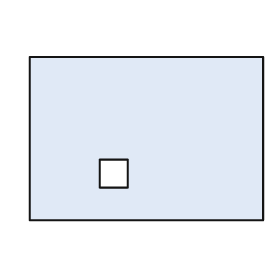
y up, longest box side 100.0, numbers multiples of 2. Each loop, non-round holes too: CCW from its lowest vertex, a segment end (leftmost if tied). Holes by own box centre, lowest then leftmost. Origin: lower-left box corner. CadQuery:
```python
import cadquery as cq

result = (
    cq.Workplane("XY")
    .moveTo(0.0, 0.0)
    .lineTo(100.0, 0.0)
    .lineTo(100.0, 70.0)
    .lineTo(0.0, 70.0)
    .close()
    .moveTo(30.0, 14.0)
    .lineTo(42.0, 14.0)
    .lineTo(42.0, 26.0)
    .lineTo(30.0, 26.0)
    .close()
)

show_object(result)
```